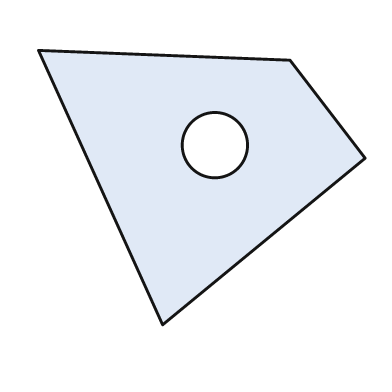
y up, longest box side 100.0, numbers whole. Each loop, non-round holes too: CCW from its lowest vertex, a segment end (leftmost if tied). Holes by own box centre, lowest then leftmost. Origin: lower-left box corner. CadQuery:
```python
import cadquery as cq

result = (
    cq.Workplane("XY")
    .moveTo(38.0, 0.0)
    .lineTo(100.0, 51.0)
    .lineTo(77.0, 81.0)
    .lineTo(0.0, 84.0)
    .close()
    .moveTo(54.0, 55.0)
    .circle(10.0)
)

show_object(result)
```